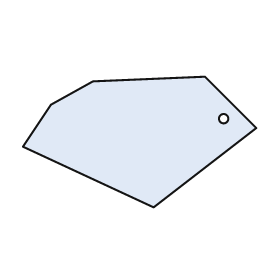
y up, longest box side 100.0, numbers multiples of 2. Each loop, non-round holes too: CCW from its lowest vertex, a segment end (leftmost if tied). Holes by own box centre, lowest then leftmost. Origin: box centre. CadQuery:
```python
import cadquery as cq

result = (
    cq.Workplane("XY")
    .moveTo(6.0, -28.0)
    .lineTo(50.0, 6.0)
    .lineTo(28.0, 28.0)
    .lineTo(-20.0, 26.0)
    .lineTo(-38.0, 16.0)
    .lineTo(-50.0, -2.0)
    .close()
    .moveTo(36.0, 10.0)
    .circle(2.0)
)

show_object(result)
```